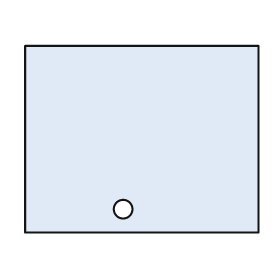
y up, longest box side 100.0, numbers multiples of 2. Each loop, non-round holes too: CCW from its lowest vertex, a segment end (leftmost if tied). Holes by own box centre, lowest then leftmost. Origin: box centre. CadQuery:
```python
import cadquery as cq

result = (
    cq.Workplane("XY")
    .moveTo(-50.0, -40.0)
    .lineTo(50.0, -40.0)
    .lineTo(50.0, 40.0)
    .lineTo(-50.0, 40.0)
    .close()
    .moveTo(-8.0, -30.0)
    .circle(4.0)
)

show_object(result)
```